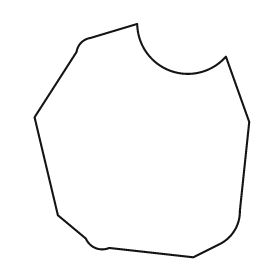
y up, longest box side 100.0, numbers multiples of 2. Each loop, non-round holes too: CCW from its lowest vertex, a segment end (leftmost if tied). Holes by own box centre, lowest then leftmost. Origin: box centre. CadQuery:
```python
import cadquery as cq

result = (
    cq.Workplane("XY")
    .moveTo(22.0, -50.0)
    .lineTo(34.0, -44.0)
    .threePointArc((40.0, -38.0), (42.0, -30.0))
    .lineTo(46.0, 8.0)
    .lineTo(36.0, 36.0)
    .threePointArc((12.0, 30.0), (-2.0, 50.0))
    .lineTo(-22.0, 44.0)
    .threePointArc((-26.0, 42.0), (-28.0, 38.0))
    .lineTo(-46.0, 10.0)
    .lineTo(-36.0, -32.0)
    .lineTo(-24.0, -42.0)
    .threePointArc((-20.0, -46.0), (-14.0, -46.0))
    .close()
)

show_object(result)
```